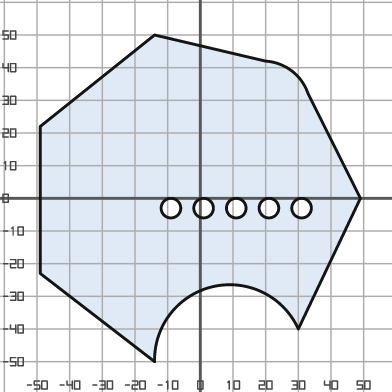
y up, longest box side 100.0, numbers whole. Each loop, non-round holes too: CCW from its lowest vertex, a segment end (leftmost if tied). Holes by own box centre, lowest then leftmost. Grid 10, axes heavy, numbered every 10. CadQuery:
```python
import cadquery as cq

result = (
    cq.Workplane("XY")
    .moveTo(-14.0, -50.0)
    .threePointArc((4.0, -27.0), (30.0, -40.0))
    .lineTo(49.0, 0.0)
    .lineTo(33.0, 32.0)
    .threePointArc((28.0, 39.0), (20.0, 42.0))
    .lineTo(-14.0, 50.0)
    .lineTo(-49.0, 22.0)
    .lineTo(-49.0, -23.0)
    .close()
    .moveTo(-9.0, -3.0)
    .circle(3.0)
    .moveTo(1.0, -3.0)
    .circle(3.0)
    .moveTo(11.0, -3.0)
    .circle(3.0)
    .moveTo(21.0, -3.0)
    .circle(3.0)
    .moveTo(31.0, -3.0)
    .circle(3.0)
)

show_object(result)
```